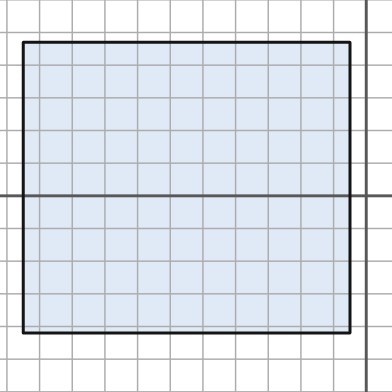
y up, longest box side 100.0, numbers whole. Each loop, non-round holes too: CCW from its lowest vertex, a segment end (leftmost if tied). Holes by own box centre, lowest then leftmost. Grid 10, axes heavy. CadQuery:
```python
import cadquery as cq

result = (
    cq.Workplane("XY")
    .moveTo(-105.0, -42.0)
    .lineTo(-5.0, -42.0)
    .lineTo(-5.0, 47.0)
    .lineTo(-105.0, 47.0)
    .close()
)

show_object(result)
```